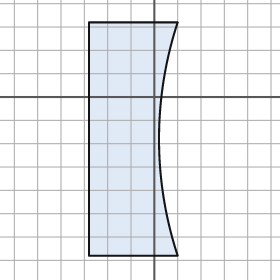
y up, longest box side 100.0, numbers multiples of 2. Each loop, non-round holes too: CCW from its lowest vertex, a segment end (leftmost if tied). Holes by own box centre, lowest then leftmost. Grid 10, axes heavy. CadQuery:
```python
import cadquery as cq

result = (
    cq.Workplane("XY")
    .moveTo(-28.0, -68.0)
    .lineTo(10.0, -68.0)
    .threePointArc((2.0, -18.0), (10.0, 32.0))
    .lineTo(-28.0, 32.0)
    .close()
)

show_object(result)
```